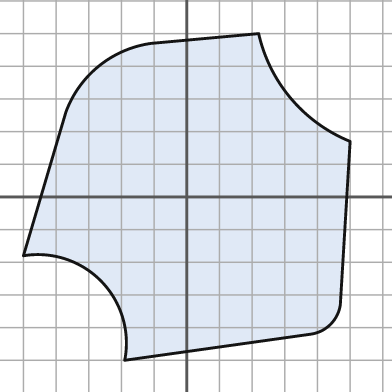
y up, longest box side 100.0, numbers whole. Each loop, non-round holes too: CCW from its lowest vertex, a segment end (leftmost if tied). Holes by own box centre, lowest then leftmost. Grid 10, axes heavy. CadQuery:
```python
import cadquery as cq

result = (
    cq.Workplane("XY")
    .moveTo(-19.0, -50.0)
    .lineTo(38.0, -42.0)
    .threePointArc((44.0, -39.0), (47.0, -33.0))
    .lineTo(50.0, 17.0)
    .threePointArc((32.0, 30.0), (22.0, 50.0))
    .lineTo(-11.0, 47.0)
    .threePointArc((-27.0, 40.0), (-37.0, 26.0))
    .lineTo(-50.0, -18.0)
    .threePointArc((-26.0, -26.0), (-19.0, -50.0))
    .close()
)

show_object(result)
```